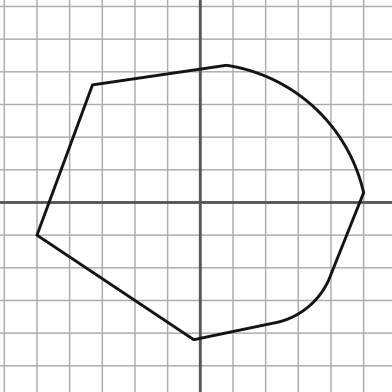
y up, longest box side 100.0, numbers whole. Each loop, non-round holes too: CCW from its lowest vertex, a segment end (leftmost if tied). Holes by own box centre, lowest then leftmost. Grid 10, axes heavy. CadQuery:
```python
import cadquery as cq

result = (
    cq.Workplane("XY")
    .moveTo(-2.0, -42.0)
    .lineTo(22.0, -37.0)
    .threePointArc((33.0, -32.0), (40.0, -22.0))
    .lineTo(50.0, 3.0)
    .threePointArc((35.0, 29.0), (8.0, 42.0))
    .lineTo(-33.0, 36.0)
    .lineTo(-50.0, -10.0)
    .close()
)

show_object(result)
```